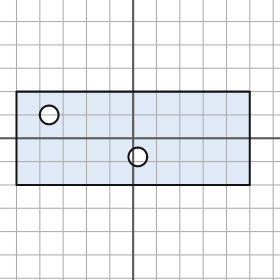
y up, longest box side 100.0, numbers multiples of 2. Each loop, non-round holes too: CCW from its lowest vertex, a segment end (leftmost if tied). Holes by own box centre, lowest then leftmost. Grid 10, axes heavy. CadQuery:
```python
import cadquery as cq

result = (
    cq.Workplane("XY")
    .moveTo(-50.0, -20.0)
    .lineTo(50.0, -20.0)
    .lineTo(50.0, 20.0)
    .lineTo(-50.0, 20.0)
    .close()
    .moveTo(2.0, -8.0)
    .circle(4.0)
    .moveTo(-36.0, 10.0)
    .circle(4.0)
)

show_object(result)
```